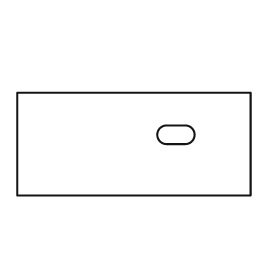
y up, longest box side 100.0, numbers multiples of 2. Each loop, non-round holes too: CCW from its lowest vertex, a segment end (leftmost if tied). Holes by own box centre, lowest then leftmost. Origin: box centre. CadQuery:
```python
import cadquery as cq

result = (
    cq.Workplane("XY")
    .moveTo(-50.0, -22.0)
    .lineTo(50.0, -22.0)
    .lineTo(50.0, 22.0)
    .lineTo(-50.0, 22.0)
    .close()
    .moveTo(14.0, 0.0)
    .lineTo(22.0, 0.0)
    .threePointArc((26.0, 4.0), (22.0, 8.0))
    .lineTo(14.0, 8.0)
    .threePointArc((10.0, 4.0), (14.0, 0.0))
    .close()
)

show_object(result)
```